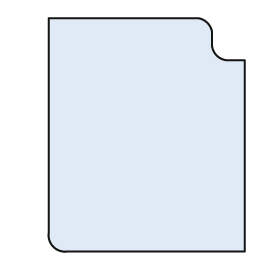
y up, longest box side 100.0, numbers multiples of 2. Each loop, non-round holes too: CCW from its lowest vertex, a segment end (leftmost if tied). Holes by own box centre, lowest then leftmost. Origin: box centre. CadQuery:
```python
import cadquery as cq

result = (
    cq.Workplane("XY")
    .moveTo(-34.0, -50.0)
    .lineTo(42.0, -50.0)
    .lineTo(42.0, 32.0)
    .lineTo(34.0, 32.0)
    .threePointArc((30.0, 34.0), (28.0, 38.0))
    .lineTo(28.0, 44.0)
    .threePointArc((26.0, 48.0), (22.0, 50.0))
    .lineTo(-42.0, 50.0)
    .lineTo(-42.0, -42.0)
    .threePointArc((-40.0, -48.0), (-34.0, -50.0))
    .close()
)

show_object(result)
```